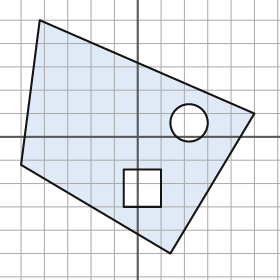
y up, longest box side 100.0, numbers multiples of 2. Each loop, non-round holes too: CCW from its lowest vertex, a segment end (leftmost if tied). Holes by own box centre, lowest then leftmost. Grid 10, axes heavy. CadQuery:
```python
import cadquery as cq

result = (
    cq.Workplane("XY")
    .moveTo(14.0, -50.0)
    .lineTo(50.0, 10.0)
    .lineTo(-42.0, 50.0)
    .lineTo(-50.0, -12.0)
    .close()
    .moveTo(-6.0, -30.0)
    .lineTo(10.0, -30.0)
    .lineTo(10.0, -14.0)
    .lineTo(-6.0, -14.0)
    .close()
    .moveTo(22.0, 6.0)
    .circle(8.0)
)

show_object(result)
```